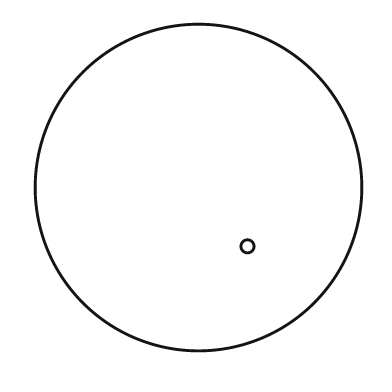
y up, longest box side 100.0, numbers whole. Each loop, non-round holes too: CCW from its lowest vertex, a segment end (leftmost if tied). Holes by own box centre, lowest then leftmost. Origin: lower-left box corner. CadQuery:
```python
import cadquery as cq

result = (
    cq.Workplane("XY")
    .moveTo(50.0, 50.0)
    .circle(50.0)
    .moveTo(65.0, 32.0)
    .circle(2.0)
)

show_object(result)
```